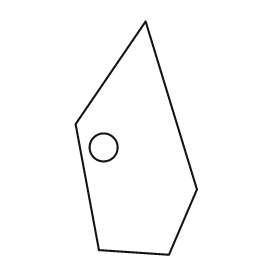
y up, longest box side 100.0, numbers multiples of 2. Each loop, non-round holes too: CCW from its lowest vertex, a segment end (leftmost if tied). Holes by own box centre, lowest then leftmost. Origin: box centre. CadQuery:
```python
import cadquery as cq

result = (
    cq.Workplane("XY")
    .moveTo(14.0, -50.0)
    .lineTo(26.0, -22.0)
    .lineTo(4.0, 50.0)
    .lineTo(-26.0, 6.0)
    .lineTo(-16.0, -48.0)
    .close()
    .moveTo(-14.0, -4.0)
    .circle(6.0)
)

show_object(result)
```